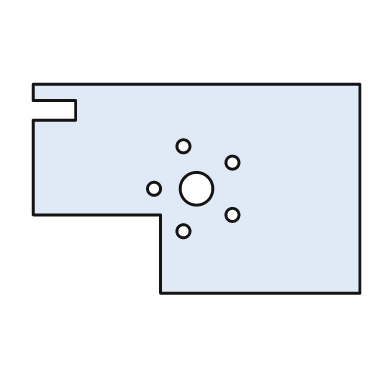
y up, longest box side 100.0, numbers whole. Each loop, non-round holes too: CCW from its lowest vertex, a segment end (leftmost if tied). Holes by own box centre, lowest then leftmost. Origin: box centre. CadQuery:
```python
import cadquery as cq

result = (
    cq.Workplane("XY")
    .moveTo(-11.0, -32.0)
    .lineTo(50.0, -32.0)
    .lineTo(50.0, 32.0)
    .lineTo(-50.0, 32.0)
    .lineTo(-50.0, 27.0)
    .lineTo(-37.0, 27.0)
    .lineTo(-37.0, 21.0)
    .lineTo(-50.0, 21.0)
    .lineTo(-50.0, -8.0)
    .lineTo(-11.0, -8.0)
    .close()
    .moveTo(-4.0, -13.0)
    .circle(2.0)
    .moveTo(11.0, -8.0)
    .circle(2.0)
    .moveTo(-13.0, 0.0)
    .circle(2.0)
    .moveTo(0.0, 0.0)
    .circle(5.0)
    .moveTo(11.0, 8.0)
    .circle(2.0)
    .moveTo(-4.0, 13.0)
    .circle(2.0)
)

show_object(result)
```